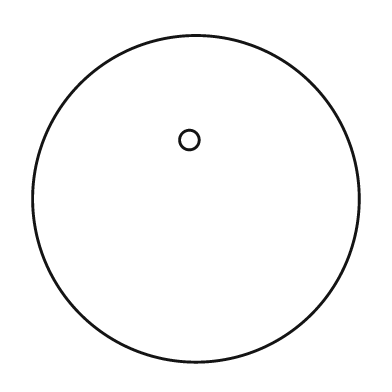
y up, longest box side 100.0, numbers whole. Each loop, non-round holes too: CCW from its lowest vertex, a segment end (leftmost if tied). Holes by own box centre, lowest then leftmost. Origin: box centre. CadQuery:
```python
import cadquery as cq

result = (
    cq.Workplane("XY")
    .moveTo(0.0, 0.0)
    .circle(50.0)
    .moveTo(-2.0, 18.0)
    .circle(3.0)
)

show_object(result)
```